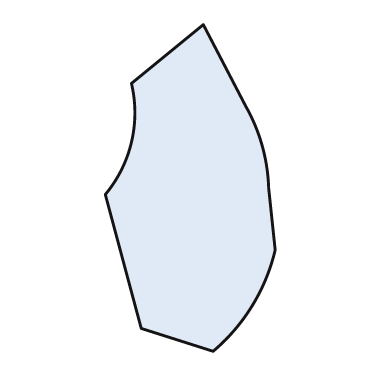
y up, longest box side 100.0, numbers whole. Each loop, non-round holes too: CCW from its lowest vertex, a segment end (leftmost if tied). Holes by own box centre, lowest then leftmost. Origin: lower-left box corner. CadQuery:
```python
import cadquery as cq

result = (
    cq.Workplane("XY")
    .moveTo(33.0, 0.0)
    .threePointArc((45.0, 14.0), (52.0, 31.0))
    .lineTo(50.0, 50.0)
    .threePointArc((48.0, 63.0), (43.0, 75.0))
    .lineTo(30.0, 100.0)
    .lineTo(8.0, 82.0)
    .threePointArc((8.0, 64.0), (0.0, 48.0))
    .lineTo(11.0, 7.0)
    .close()
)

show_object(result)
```